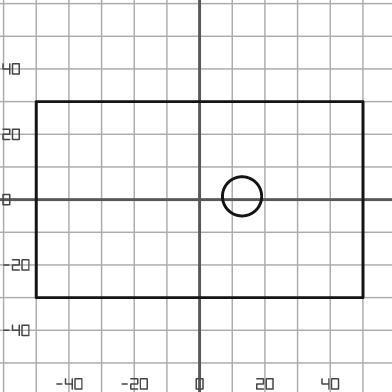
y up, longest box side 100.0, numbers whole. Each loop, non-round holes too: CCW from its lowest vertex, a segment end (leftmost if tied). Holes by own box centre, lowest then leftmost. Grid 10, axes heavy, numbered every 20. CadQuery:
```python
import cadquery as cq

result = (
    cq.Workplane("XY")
    .moveTo(-50.0, -30.0)
    .lineTo(50.0, -30.0)
    .lineTo(50.0, 30.0)
    .lineTo(-50.0, 30.0)
    .close()
    .moveTo(13.0, 1.0)
    .circle(6.0)
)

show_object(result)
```